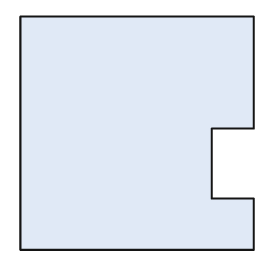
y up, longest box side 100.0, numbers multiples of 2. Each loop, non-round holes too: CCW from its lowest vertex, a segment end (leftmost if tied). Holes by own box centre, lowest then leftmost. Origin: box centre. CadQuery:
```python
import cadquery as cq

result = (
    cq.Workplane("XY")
    .moveTo(-50.0, -50.0)
    .lineTo(50.0, -50.0)
    .lineTo(50.0, -28.0)
    .lineTo(32.0, -28.0)
    .lineTo(32.0, 2.0)
    .lineTo(50.0, 2.0)
    .lineTo(50.0, 50.0)
    .lineTo(-50.0, 50.0)
    .close()
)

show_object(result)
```